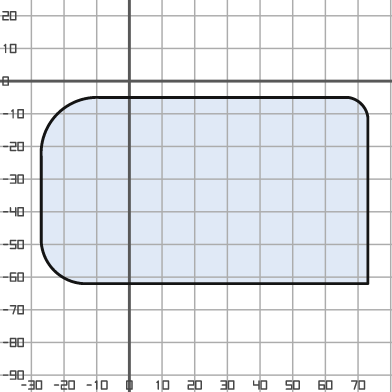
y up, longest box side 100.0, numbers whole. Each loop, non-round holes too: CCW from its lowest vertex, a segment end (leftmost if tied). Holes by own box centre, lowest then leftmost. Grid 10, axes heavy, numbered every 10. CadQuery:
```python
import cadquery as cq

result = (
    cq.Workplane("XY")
    .moveTo(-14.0, -62.0)
    .lineTo(73.0, -62.0)
    .lineTo(73.0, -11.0)
    .threePointArc((71.0, -7.0), (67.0, -5.0))
    .lineTo(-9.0, -5.0)
    .threePointArc((-22.0, -10.0), (-27.0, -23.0))
    .lineTo(-27.0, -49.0)
    .threePointArc((-23.0, -58.0), (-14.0, -62.0))
    .close()
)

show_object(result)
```